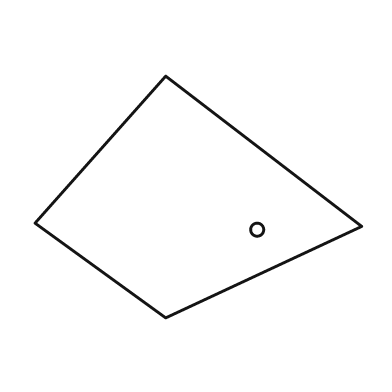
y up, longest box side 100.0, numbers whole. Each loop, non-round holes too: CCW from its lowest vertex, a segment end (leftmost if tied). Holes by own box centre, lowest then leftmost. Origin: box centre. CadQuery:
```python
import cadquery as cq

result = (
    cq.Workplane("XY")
    .moveTo(-10.0, -37.0)
    .lineTo(50.0, -9.0)
    .lineTo(-10.0, 37.0)
    .lineTo(-50.0, -8.0)
    .close()
    .moveTo(18.0, -10.0)
    .circle(2.0)
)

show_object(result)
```